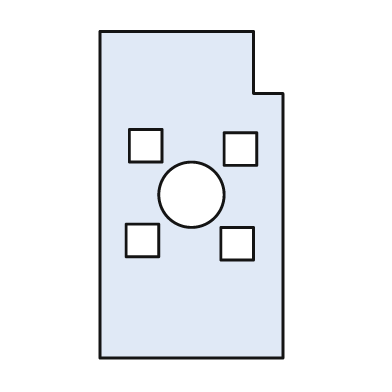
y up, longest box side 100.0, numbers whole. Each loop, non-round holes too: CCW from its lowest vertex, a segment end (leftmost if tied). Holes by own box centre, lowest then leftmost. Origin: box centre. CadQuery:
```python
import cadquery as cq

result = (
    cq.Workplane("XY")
    .moveTo(-28.0, -50.0)
    .lineTo(28.0, -50.0)
    .lineTo(28.0, 31.0)
    .lineTo(19.0, 31.0)
    .lineTo(19.0, 50.0)
    .lineTo(-28.0, 50.0)
    .close()
    .moveTo(9.0, -20.0)
    .lineTo(19.0, -20.0)
    .lineTo(19.0, -10.0)
    .lineTo(9.0, -10.0)
    .close()
    .moveTo(-20.0, -19.0)
    .lineTo(-10.0, -19.0)
    .lineTo(-10.0, -9.0)
    .lineTo(-20.0, -9.0)
    .close()
    .moveTo(0.0, 0.0)
    .circle(10.0)
    .moveTo(10.0, 9.0)
    .lineTo(20.0, 9.0)
    .lineTo(20.0, 19.0)
    .lineTo(10.0, 19.0)
    .close()
    .moveTo(-19.0, 10.0)
    .lineTo(-9.0, 10.0)
    .lineTo(-9.0, 20.0)
    .lineTo(-19.0, 20.0)
    .close()
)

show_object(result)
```